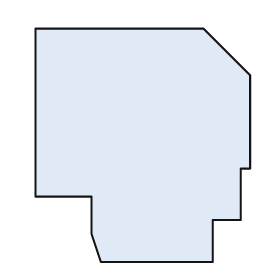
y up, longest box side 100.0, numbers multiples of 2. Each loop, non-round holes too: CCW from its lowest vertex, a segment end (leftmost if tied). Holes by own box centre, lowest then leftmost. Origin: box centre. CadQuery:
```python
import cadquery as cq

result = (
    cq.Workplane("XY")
    .moveTo(-18.0, -50.0)
    .lineTo(30.0, -50.0)
    .lineTo(30.0, -32.0)
    .lineTo(42.0, -32.0)
    .lineTo(42.0, -10.0)
    .lineTo(46.0, -10.0)
    .lineTo(46.0, 30.0)
    .lineTo(26.0, 50.0)
    .lineTo(-46.0, 50.0)
    .lineTo(-46.0, -22.0)
    .lineTo(-22.0, -22.0)
    .lineTo(-22.0, -38.0)
    .close()
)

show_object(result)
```